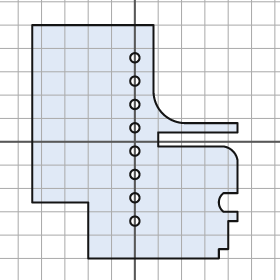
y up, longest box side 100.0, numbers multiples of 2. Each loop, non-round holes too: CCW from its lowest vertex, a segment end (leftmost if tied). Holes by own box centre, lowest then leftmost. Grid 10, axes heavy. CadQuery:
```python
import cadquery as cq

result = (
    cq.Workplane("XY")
    .moveTo(-20.0, -50.0)
    .lineTo(36.0, -50.0)
    .lineTo(36.0, -46.0)
    .lineTo(40.0, -46.0)
    .lineTo(40.0, -34.0)
    .lineTo(44.0, -34.0)
    .lineTo(44.0, -30.0)
    .lineTo(38.0, -30.0)
    .threePointArc((36.0, -26.0), (38.0, -22.0))
    .lineTo(44.0, -22.0)
    .lineTo(44.0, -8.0)
    .threePointArc((42.0, -4.0), (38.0, -2.0))
    .lineTo(10.0, -2.0)
    .lineTo(10.0, 4.0)
    .lineTo(44.0, 4.0)
    .lineTo(44.0, 8.0)
    .lineTo(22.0, 8.0)
    .threePointArc((12.0, 12.0), (8.0, 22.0))
    .lineTo(8.0, 50.0)
    .lineTo(-44.0, 50.0)
    .lineTo(-44.0, -26.0)
    .lineTo(-20.0, -26.0)
    .close()
    .moveTo(0.0, -34.0)
    .circle(2.0)
    .moveTo(0.0, -24.0)
    .circle(2.0)
    .moveTo(0.0, -14.0)
    .circle(2.0)
    .moveTo(0.0, -4.0)
    .circle(2.0)
    .moveTo(0.0, 6.0)
    .circle(2.0)
    .moveTo(0.0, 16.0)
    .circle(2.0)
    .moveTo(0.0, 26.0)
    .circle(2.0)
    .moveTo(0.0, 36.0)
    .circle(2.0)
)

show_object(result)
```